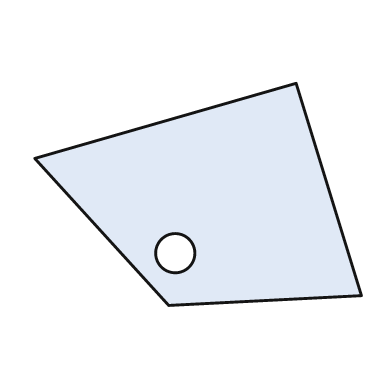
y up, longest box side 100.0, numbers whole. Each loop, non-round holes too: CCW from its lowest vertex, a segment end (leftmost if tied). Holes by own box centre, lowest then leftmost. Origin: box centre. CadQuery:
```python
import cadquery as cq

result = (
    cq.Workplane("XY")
    .moveTo(-9.0, -34.0)
    .lineTo(50.0, -31.0)
    .lineTo(30.0, 34.0)
    .lineTo(-50.0, 11.0)
    .close()
    .moveTo(-7.0, -18.0)
    .circle(6.0)
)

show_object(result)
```